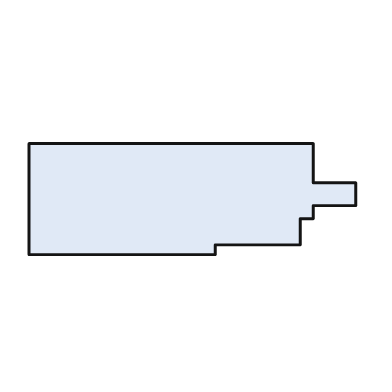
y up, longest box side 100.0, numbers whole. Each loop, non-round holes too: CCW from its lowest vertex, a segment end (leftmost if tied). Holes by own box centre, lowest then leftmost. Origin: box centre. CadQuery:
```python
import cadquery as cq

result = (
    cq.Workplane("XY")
    .moveTo(-50.0, -17.0)
    .lineTo(7.0, -17.0)
    .lineTo(7.0, -14.0)
    .lineTo(33.0, -14.0)
    .lineTo(33.0, -6.0)
    .lineTo(37.0, -6.0)
    .lineTo(37.0, -2.0)
    .lineTo(50.0, -2.0)
    .lineTo(50.0, 5.0)
    .lineTo(37.0, 5.0)
    .lineTo(37.0, 17.0)
    .lineTo(-50.0, 17.0)
    .close()
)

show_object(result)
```